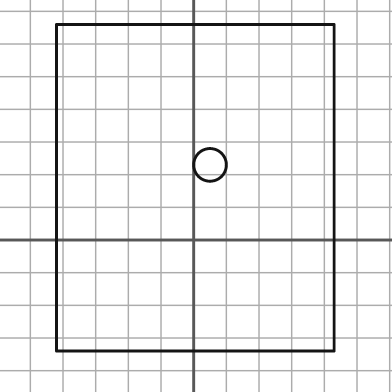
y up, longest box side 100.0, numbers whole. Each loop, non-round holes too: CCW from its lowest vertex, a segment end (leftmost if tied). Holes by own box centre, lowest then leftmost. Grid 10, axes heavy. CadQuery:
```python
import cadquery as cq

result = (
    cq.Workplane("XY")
    .moveTo(-42.0, -34.0)
    .lineTo(43.0, -34.0)
    .lineTo(43.0, 66.0)
    .lineTo(-42.0, 66.0)
    .close()
    .moveTo(5.0, 23.0)
    .circle(5.0)
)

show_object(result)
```